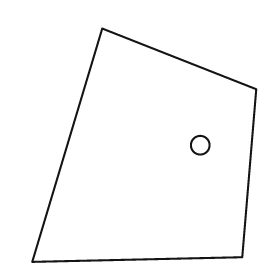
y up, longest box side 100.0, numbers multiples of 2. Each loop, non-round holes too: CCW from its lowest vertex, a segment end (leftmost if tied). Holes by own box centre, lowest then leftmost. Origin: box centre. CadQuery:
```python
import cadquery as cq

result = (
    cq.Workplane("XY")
    .moveTo(-48.0, -50.0)
    .lineTo(42.0, -48.0)
    .lineTo(48.0, 24.0)
    .lineTo(-18.0, 50.0)
    .close()
    .moveTo(24.0, 0.0)
    .circle(4.0)
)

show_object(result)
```